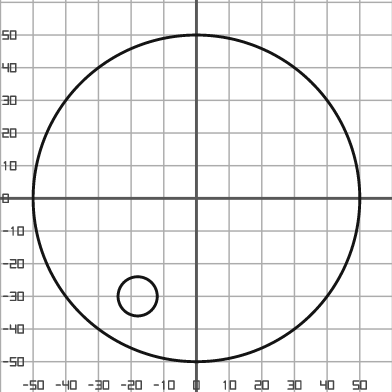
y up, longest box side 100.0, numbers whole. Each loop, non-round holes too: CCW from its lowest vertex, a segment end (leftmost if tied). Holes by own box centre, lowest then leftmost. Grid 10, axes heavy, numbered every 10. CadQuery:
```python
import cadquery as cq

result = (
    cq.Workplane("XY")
    .moveTo(0.0, 0.0)
    .circle(50.0)
    .moveTo(-18.0, -30.0)
    .circle(6.0)
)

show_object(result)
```